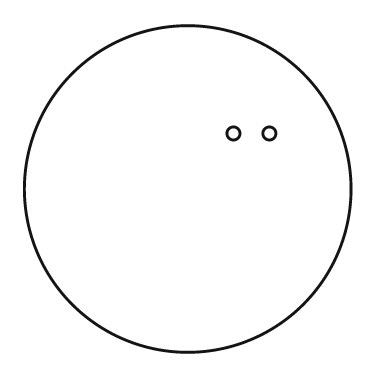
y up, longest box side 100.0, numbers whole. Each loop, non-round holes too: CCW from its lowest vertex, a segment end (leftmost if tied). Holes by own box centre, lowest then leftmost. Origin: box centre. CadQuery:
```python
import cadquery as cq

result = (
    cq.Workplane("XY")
    .moveTo(0.0, 0.0)
    .circle(50.0)
    .moveTo(14.0, 17.0)
    .circle(2.0)
    .moveTo(25.0, 17.0)
    .circle(2.0)
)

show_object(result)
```